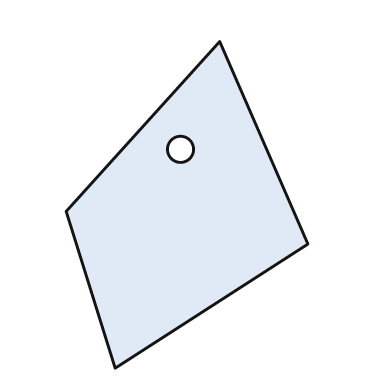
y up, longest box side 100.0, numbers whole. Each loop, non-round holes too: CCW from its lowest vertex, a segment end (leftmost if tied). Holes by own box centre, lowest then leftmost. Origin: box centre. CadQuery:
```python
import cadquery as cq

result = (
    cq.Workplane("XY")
    .moveTo(-22.0, -50.0)
    .lineTo(37.0, -12.0)
    .lineTo(10.0, 50.0)
    .lineTo(-37.0, -2.0)
    .close()
    .moveTo(-2.0, 17.0)
    .circle(4.0)
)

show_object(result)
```